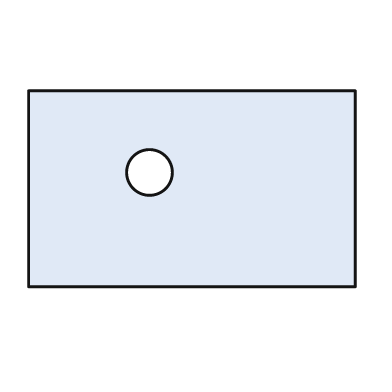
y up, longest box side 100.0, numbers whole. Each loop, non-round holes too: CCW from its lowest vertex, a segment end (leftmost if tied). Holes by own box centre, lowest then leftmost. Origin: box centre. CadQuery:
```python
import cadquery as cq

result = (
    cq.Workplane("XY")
    .moveTo(-50.0, -30.0)
    .lineTo(50.0, -30.0)
    .lineTo(50.0, 30.0)
    .lineTo(-50.0, 30.0)
    .close()
    .moveTo(-13.0, 5.0)
    .circle(7.0)
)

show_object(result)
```